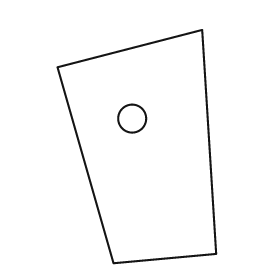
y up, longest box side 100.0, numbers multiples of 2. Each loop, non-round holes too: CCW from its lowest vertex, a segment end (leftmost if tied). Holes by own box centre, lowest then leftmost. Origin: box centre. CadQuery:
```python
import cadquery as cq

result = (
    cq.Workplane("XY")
    .moveTo(-10.0, -50.0)
    .lineTo(34.0, -46.0)
    .lineTo(28.0, 50.0)
    .lineTo(-34.0, 34.0)
    .close()
    .moveTo(-2.0, 12.0)
    .circle(6.0)
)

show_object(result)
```